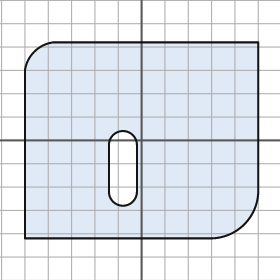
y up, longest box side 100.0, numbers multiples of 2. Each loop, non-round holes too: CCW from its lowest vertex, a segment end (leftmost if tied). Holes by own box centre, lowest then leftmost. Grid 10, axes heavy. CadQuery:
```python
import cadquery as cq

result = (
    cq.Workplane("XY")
    .moveTo(-50.0, -42.0)
    .lineTo(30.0, -42.0)
    .threePointArc((44.0, -36.0), (50.0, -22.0))
    .lineTo(50.0, 42.0)
    .lineTo(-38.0, 42.0)
    .threePointArc((-46.0, 38.0), (-50.0, 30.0))
    .close()
    .moveTo(-14.0, -22.0)
    .threePointArc((-8.0, -28.0), (-2.0, -22.0))
    .lineTo(-2.0, -2.0)
    .threePointArc((-8.0, 4.0), (-14.0, -2.0))
    .close()
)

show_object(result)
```